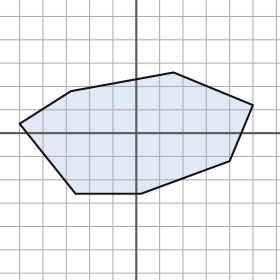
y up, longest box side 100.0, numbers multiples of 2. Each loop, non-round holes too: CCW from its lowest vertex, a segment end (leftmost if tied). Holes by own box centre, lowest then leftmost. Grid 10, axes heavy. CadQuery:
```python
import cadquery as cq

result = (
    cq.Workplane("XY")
    .moveTo(-26.0, -26.0)
    .lineTo(2.0, -26.0)
    .lineTo(40.0, -12.0)
    .lineTo(50.0, 12.0)
    .lineTo(16.0, 26.0)
    .lineTo(-28.0, 18.0)
    .lineTo(-50.0, 4.0)
    .close()
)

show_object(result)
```